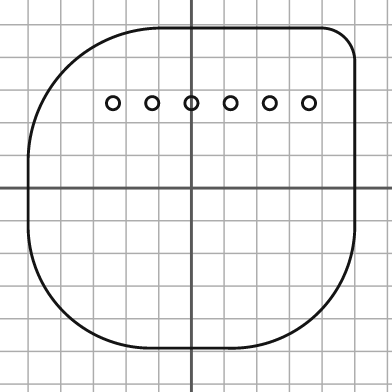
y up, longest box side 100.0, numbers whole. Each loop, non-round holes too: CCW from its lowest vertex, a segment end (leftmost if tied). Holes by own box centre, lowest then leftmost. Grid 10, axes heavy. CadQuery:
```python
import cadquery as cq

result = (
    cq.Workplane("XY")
    .moveTo(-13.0, -49.0)
    .lineTo(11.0, -49.0)
    .threePointArc((39.0, -38.0), (50.0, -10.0))
    .lineTo(50.0, 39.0)
    .threePointArc((47.0, 46.0), (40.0, 49.0))
    .lineTo(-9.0, 49.0)
    .threePointArc((-38.0, 37.0), (-50.0, 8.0))
    .lineTo(-50.0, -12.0)
    .threePointArc((-39.0, -38.0), (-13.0, -49.0))
    .close()
    .moveTo(-24.0, 26.0)
    .circle(2.0)
    .moveTo(-12.0, 26.0)
    .circle(2.0)
    .moveTo(0.0, 26.0)
    .circle(2.0)
    .moveTo(12.0, 26.0)
    .circle(2.0)
    .moveTo(24.0, 26.0)
    .circle(2.0)
    .moveTo(36.0, 26.0)
    .circle(2.0)
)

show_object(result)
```